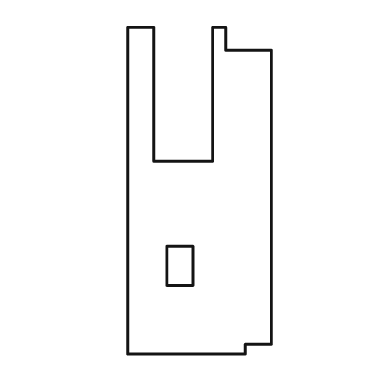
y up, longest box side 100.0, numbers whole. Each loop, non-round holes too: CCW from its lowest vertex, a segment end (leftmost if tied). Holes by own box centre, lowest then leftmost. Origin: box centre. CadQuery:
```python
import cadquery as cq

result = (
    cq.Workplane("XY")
    .moveTo(-22.0, -50.0)
    .lineTo(14.0, -50.0)
    .lineTo(14.0, -47.0)
    .lineTo(22.0, -47.0)
    .lineTo(22.0, 43.0)
    .lineTo(8.0, 43.0)
    .lineTo(8.0, 50.0)
    .lineTo(4.0, 50.0)
    .lineTo(4.0, 9.0)
    .lineTo(-14.0, 9.0)
    .lineTo(-14.0, 50.0)
    .lineTo(-22.0, 50.0)
    .close()
    .moveTo(-10.0, -29.0)
    .lineTo(-2.0, -29.0)
    .lineTo(-2.0, -17.0)
    .lineTo(-10.0, -17.0)
    .close()
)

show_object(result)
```